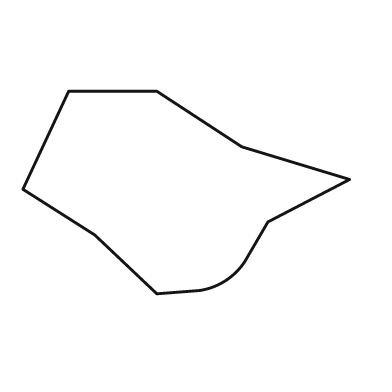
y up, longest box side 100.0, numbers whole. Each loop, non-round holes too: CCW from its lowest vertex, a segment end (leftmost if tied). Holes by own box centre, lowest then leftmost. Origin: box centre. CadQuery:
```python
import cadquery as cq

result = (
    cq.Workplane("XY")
    .moveTo(-9.0, -31.0)
    .lineTo(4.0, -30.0)
    .threePointArc((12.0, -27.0), (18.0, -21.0))
    .lineTo(25.0, -9.0)
    .lineTo(50.0, 4.0)
    .lineTo(17.0, 14.0)
    .lineTo(-9.0, 31.0)
    .lineTo(-36.0, 31.0)
    .lineTo(-50.0, 1.0)
    .lineTo(-28.0, -13.0)
    .close()
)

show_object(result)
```